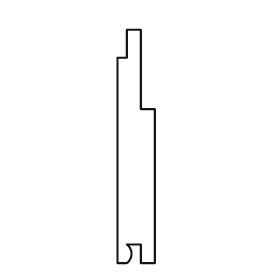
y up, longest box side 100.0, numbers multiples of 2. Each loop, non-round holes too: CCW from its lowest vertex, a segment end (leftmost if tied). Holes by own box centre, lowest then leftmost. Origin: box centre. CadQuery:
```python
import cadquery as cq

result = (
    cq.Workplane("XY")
    .moveTo(-8.0, -50.0)
    .lineTo(-4.0, -50.0)
    .threePointArc((-2.0, -46.0), (-4.0, -42.0))
    .lineTo(2.0, -42.0)
    .lineTo(2.0, -50.0)
    .lineTo(8.0, -50.0)
    .lineTo(8.0, 16.0)
    .lineTo(2.0, 16.0)
    .lineTo(2.0, 50.0)
    .lineTo(-4.0, 50.0)
    .lineTo(-4.0, 38.0)
    .lineTo(-8.0, 38.0)
    .close()
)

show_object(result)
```